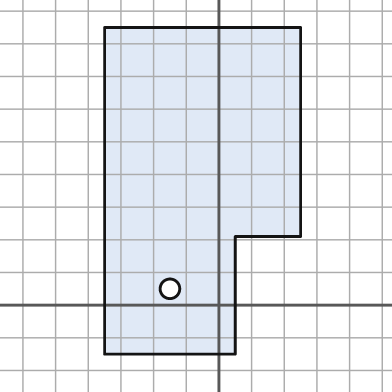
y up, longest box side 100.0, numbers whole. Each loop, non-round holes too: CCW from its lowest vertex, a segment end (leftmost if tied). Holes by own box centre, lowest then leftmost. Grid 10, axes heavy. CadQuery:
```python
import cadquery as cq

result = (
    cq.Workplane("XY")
    .moveTo(-35.0, -15.0)
    .lineTo(5.0, -15.0)
    .lineTo(5.0, 21.0)
    .lineTo(25.0, 21.0)
    .lineTo(25.0, 85.0)
    .lineTo(-35.0, 85.0)
    .close()
    .moveTo(-15.0, 5.0)
    .circle(3.0)
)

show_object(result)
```